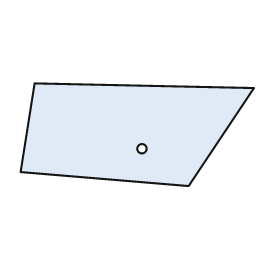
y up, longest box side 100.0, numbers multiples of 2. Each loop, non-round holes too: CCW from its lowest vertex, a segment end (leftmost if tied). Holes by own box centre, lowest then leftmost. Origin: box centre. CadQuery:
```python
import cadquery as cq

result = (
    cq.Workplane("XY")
    .moveTo(22.0, -22.0)
    .lineTo(50.0, 20.0)
    .lineTo(-44.0, 22.0)
    .lineTo(-50.0, -16.0)
    .close()
    .moveTo(2.0, -6.0)
    .circle(2.0)
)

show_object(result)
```